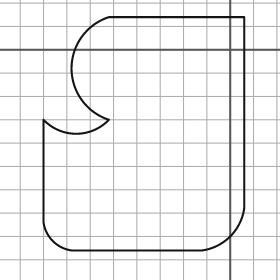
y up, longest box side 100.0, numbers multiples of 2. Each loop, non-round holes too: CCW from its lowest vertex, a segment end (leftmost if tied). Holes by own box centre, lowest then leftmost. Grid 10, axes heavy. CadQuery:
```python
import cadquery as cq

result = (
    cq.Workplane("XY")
    .moveTo(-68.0, -86.0)
    .lineTo(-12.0, -86.0)
    .threePointArc((0.0, -80.0), (6.0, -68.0))
    .lineTo(6.0, 14.0)
    .lineTo(-52.0, 14.0)
    .threePointArc((-68.0, -8.0), (-52.0, -30.0))
    .threePointArc((-66.0, -36.0), (-80.0, -30.0))
    .lineTo(-80.0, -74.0)
    .threePointArc((-76.0, -82.0), (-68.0, -86.0))
    .close()
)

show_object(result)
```